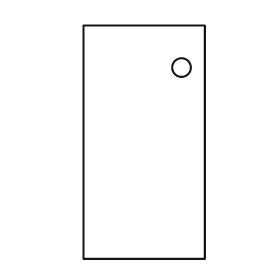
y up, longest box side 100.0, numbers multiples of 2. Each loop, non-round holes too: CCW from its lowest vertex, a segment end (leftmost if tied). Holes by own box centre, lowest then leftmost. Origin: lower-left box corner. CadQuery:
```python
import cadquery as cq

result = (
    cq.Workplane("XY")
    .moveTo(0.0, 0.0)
    .lineTo(52.0, 0.0)
    .lineTo(52.0, 100.0)
    .lineTo(0.0, 100.0)
    .close()
    .moveTo(42.0, 82.0)
    .circle(4.0)
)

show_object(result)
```